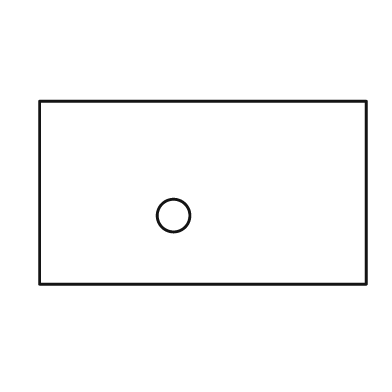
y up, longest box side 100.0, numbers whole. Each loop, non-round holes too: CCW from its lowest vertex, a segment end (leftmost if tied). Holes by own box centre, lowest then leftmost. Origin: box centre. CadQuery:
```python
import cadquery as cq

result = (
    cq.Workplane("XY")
    .moveTo(-50.0, -28.0)
    .lineTo(50.0, -28.0)
    .lineTo(50.0, 28.0)
    .lineTo(-50.0, 28.0)
    .close()
    .moveTo(-9.0, -7.0)
    .circle(5.0)
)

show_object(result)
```